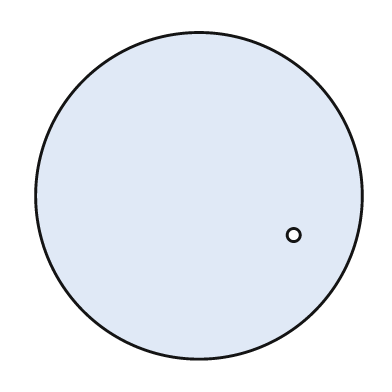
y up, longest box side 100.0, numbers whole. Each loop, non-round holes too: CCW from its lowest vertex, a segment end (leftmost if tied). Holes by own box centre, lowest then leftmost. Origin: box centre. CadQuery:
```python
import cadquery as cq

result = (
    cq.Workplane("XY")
    .moveTo(0.0, 0.0)
    .circle(50.0)
    .moveTo(29.0, -12.0)
    .circle(2.0)
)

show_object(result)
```